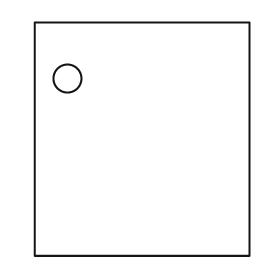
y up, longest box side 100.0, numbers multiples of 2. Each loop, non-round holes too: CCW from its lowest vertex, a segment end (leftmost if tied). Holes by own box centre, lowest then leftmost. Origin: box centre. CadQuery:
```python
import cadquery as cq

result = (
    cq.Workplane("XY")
    .moveTo(-46.0, -50.0)
    .lineTo(46.0, -50.0)
    .lineTo(46.0, 50.0)
    .lineTo(-46.0, 50.0)
    .close()
    .moveTo(-32.0, 26.0)
    .circle(6.0)
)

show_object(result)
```